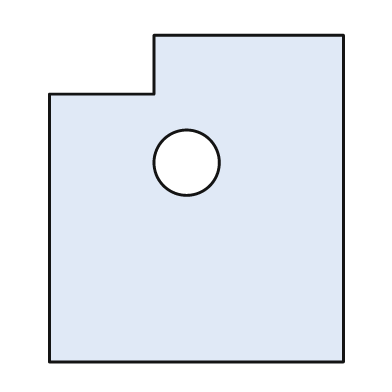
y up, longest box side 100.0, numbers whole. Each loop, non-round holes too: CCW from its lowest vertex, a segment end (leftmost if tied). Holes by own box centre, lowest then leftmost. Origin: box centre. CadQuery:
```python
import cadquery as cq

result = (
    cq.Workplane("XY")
    .moveTo(-45.0, -50.0)
    .lineTo(45.0, -50.0)
    .lineTo(45.0, 50.0)
    .lineTo(-13.0, 50.0)
    .lineTo(-13.0, 32.0)
    .lineTo(-45.0, 32.0)
    .close()
    .moveTo(-3.0, 11.0)
    .circle(10.0)
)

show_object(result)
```